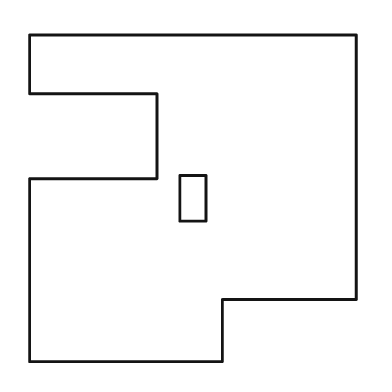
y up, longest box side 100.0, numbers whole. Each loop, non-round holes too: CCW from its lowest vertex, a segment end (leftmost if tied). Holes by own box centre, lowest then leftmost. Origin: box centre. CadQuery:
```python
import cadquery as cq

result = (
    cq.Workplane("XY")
    .moveTo(-50.0, -50.0)
    .lineTo(9.0, -50.0)
    .lineTo(9.0, -31.0)
    .lineTo(50.0, -31.0)
    .lineTo(50.0, 50.0)
    .lineTo(-50.0, 50.0)
    .lineTo(-50.0, 32.0)
    .lineTo(-11.0, 32.0)
    .lineTo(-11.0, 6.0)
    .lineTo(-50.0, 6.0)
    .close()
    .moveTo(-4.0, -7.0)
    .lineTo(4.0, -7.0)
    .lineTo(4.0, 7.0)
    .lineTo(-4.0, 7.0)
    .close()
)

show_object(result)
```